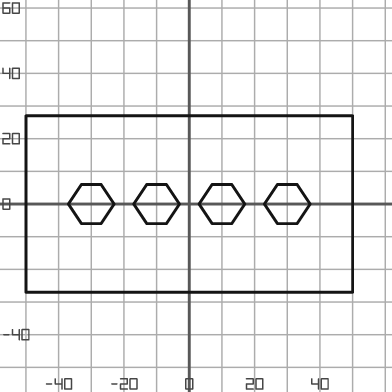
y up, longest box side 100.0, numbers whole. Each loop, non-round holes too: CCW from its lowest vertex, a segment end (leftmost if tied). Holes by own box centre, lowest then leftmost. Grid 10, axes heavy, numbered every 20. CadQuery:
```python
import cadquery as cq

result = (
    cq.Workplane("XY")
    .moveTo(-50.0, -27.0)
    .lineTo(50.0, -27.0)
    .lineTo(50.0, 27.0)
    .lineTo(-50.0, 27.0)
    .close()
    .moveTo(-33.0, -6.0)
    .lineTo(-27.0, -6.0)
    .lineTo(-23.0, 0.0)
    .lineTo(-27.0, 6.0)
    .lineTo(-33.0, 6.0)
    .lineTo(-37.0, 0.0)
    .close()
    .moveTo(-13.0, -6.0)
    .lineTo(-7.0, -6.0)
    .lineTo(-3.0, 0.0)
    .lineTo(-7.0, 6.0)
    .lineTo(-13.0, 6.0)
    .lineTo(-17.0, 0.0)
    .close()
    .moveTo(7.0, -6.0)
    .lineTo(13.0, -6.0)
    .lineTo(17.0, 0.0)
    .lineTo(13.0, 6.0)
    .lineTo(7.0, 6.0)
    .lineTo(3.0, 0.0)
    .close()
    .moveTo(27.0, -6.0)
    .lineTo(33.0, -6.0)
    .lineTo(37.0, 0.0)
    .lineTo(33.0, 6.0)
    .lineTo(27.0, 6.0)
    .lineTo(23.0, 0.0)
    .close()
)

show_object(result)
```